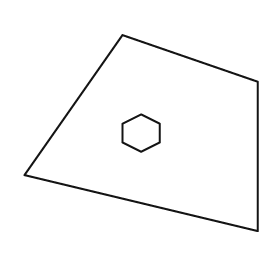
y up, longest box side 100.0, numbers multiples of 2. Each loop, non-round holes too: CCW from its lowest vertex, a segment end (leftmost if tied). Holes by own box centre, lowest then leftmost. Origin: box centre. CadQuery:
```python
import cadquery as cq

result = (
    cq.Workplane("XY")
    .moveTo(50.0, -42.0)
    .lineTo(50.0, 22.0)
    .lineTo(-8.0, 42.0)
    .lineTo(-50.0, -18.0)
    .close()
    .moveTo(0.0, -8.0)
    .lineTo(8.0, -4.0)
    .lineTo(8.0, 4.0)
    .lineTo(0.0, 8.0)
    .lineTo(-8.0, 4.0)
    .lineTo(-8.0, -4.0)
    .close()
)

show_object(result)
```